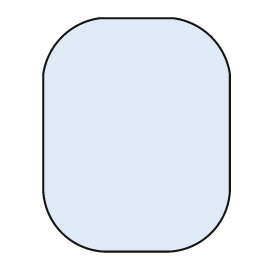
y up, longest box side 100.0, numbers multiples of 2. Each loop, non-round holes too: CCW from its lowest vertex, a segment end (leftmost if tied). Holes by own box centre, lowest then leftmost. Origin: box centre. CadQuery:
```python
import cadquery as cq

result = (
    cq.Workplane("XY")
    .moveTo(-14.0, -50.0)
    .lineTo(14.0, -50.0)
    .threePointArc((32.0, -42.0), (40.0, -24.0))
    .lineTo(40.0, 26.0)
    .threePointArc((32.0, 42.0), (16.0, 50.0))
    .lineTo(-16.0, 50.0)
    .threePointArc((-32.0, 42.0), (-40.0, 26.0))
    .lineTo(-40.0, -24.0)
    .threePointArc((-32.0, -42.0), (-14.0, -50.0))
    .close()
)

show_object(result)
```